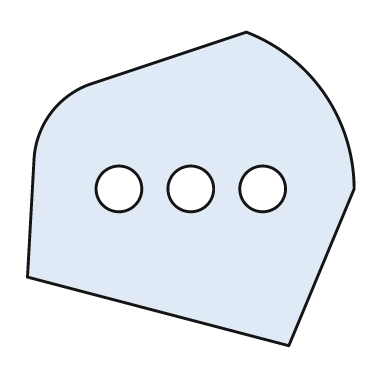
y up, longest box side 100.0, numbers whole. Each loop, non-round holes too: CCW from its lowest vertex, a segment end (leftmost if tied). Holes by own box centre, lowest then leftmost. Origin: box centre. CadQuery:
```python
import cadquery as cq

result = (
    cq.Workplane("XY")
    .moveTo(30.0, -48.0)
    .lineTo(50.0, 0.0)
    .threePointArc((41.0, 29.0), (17.0, 48.0))
    .lineTo(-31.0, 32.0)
    .threePointArc((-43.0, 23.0), (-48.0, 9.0))
    .lineTo(-50.0, -27.0)
    .close()
    .moveTo(-22.0, 0.0)
    .circle(7.0)
    .moveTo(0.0, 0.0)
    .circle(7.0)
    .moveTo(22.0, 0.0)
    .circle(7.0)
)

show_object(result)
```